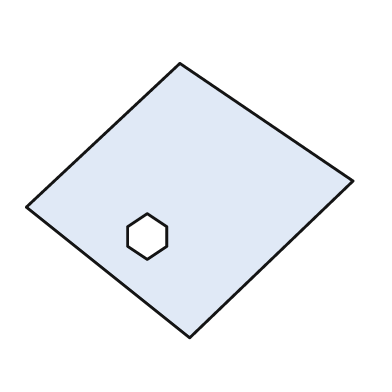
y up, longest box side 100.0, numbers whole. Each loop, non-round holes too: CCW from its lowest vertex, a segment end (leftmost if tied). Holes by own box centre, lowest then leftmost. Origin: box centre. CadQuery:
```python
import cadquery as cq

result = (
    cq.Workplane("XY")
    .moveTo(0.0, -42.0)
    .lineTo(50.0, 6.0)
    .lineTo(-3.0, 42.0)
    .lineTo(-50.0, -2.0)
    .close()
    .moveTo(-13.0, -18.0)
    .lineTo(-7.0, -14.0)
    .lineTo(-7.0, -8.0)
    .lineTo(-13.0, -4.0)
    .lineTo(-19.0, -8.0)
    .lineTo(-19.0, -14.0)
    .close()
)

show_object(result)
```